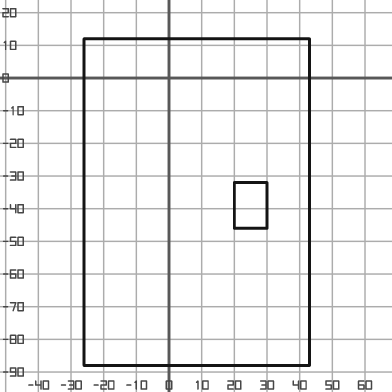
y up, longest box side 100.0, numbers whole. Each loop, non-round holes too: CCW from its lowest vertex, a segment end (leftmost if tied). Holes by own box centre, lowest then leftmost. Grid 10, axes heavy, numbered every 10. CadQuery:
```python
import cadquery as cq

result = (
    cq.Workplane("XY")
    .moveTo(-26.0, -88.0)
    .lineTo(43.0, -88.0)
    .lineTo(43.0, 12.0)
    .lineTo(-26.0, 12.0)
    .close()
    .moveTo(20.0, -46.0)
    .lineTo(30.0, -46.0)
    .lineTo(30.0, -32.0)
    .lineTo(20.0, -32.0)
    .close()
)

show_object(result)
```